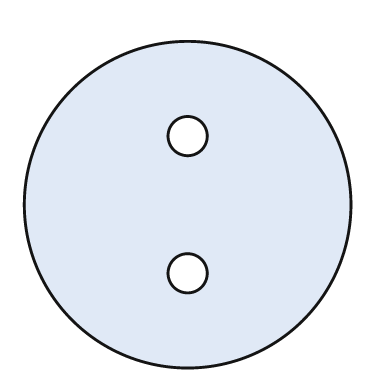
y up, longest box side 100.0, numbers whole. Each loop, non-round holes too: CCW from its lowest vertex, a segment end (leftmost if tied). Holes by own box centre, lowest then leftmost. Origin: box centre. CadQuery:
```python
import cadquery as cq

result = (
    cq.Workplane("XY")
    .moveTo(0.0, 0.0)
    .circle(50.0)
    .moveTo(0.0, -21.0)
    .circle(6.0)
    .moveTo(0.0, 21.0)
    .circle(6.0)
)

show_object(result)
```